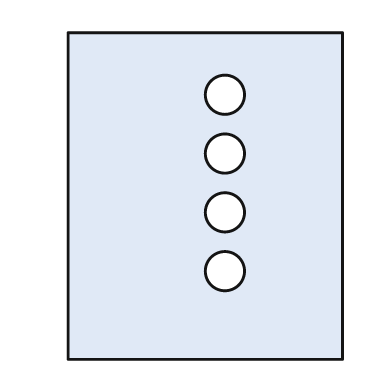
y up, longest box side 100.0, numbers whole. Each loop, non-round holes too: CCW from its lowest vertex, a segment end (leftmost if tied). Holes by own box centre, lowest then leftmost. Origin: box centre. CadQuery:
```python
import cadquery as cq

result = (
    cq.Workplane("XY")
    .moveTo(-42.0, -50.0)
    .lineTo(42.0, -50.0)
    .lineTo(42.0, 50.0)
    .lineTo(-42.0, 50.0)
    .close()
    .moveTo(6.0, -23.0)
    .circle(6.0)
    .moveTo(6.0, -5.0)
    .circle(6.0)
    .moveTo(6.0, 13.0)
    .circle(6.0)
    .moveTo(6.0, 31.0)
    .circle(6.0)
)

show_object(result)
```